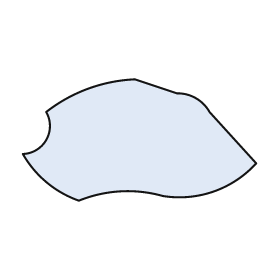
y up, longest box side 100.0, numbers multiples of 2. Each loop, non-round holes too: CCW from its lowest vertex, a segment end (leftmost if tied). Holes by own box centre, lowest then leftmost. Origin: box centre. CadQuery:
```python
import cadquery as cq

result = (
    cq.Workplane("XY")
    .moveTo(-26.0, -26.0)
    .threePointArc((-8.0, -22.0), (10.0, -24.0))
    .threePointArc((32.0, -22.0), (50.0, -10.0))
    .lineTo(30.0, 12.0)
    .threePointArc((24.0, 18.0), (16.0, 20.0))
    .lineTo(-2.0, 26.0)
    .threePointArc((-22.0, 22.0), (-40.0, 12.0))
    .threePointArc((-40.0, 0.0), (-50.0, -6.0))
    .threePointArc((-40.0, -18.0), (-26.0, -26.0))
    .close()
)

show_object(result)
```